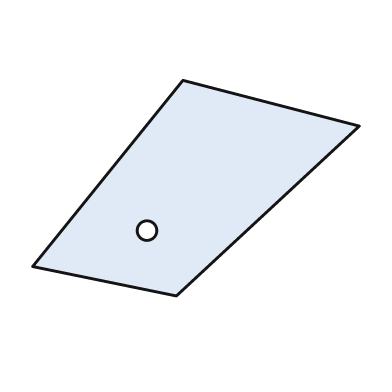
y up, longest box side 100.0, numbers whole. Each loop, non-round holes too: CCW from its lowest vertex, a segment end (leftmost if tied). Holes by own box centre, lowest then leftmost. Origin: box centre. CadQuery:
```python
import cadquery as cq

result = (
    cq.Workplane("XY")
    .moveTo(-6.0, -33.0)
    .lineTo(50.0, 19.0)
    .lineTo(-4.0, 33.0)
    .lineTo(-50.0, -24.0)
    .close()
    .moveTo(-15.0, -13.0)
    .circle(3.0)
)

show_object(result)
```